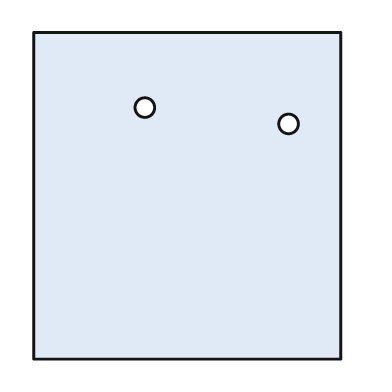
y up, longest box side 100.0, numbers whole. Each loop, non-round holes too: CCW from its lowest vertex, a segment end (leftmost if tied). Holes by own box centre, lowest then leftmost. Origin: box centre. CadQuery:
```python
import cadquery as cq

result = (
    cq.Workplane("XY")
    .moveTo(-47.0, -50.0)
    .lineTo(47.0, -50.0)
    .lineTo(47.0, 50.0)
    .lineTo(-47.0, 50.0)
    .close()
    .moveTo(31.0, 22.0)
    .circle(3.0)
    .moveTo(-13.0, 27.0)
    .circle(3.0)
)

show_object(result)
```